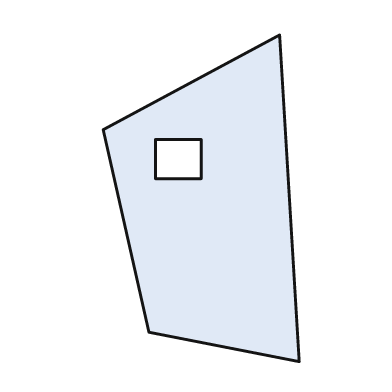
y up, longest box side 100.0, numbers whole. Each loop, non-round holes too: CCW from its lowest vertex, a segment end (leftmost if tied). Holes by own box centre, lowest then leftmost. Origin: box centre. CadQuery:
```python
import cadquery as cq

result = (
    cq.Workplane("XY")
    .moveTo(30.0, -50.0)
    .lineTo(24.0, 50.0)
    .lineTo(-30.0, 21.0)
    .lineTo(-16.0, -41.0)
    .close()
    .moveTo(-14.0, 6.0)
    .lineTo(0.0, 6.0)
    .lineTo(0.0, 18.0)
    .lineTo(-14.0, 18.0)
    .close()
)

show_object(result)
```